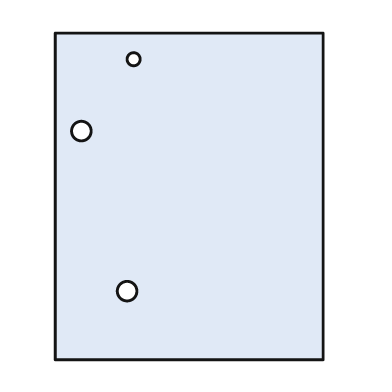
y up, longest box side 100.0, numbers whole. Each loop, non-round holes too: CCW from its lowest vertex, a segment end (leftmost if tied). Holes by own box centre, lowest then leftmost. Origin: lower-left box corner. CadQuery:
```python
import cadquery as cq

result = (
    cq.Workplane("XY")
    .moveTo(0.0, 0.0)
    .lineTo(82.0, 0.0)
    .lineTo(82.0, 100.0)
    .lineTo(0.0, 100.0)
    .close()
    .moveTo(22.0, 21.0)
    .circle(3.0)
    .moveTo(8.0, 70.0)
    .circle(3.0)
    .moveTo(24.0, 92.0)
    .circle(2.0)
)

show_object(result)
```